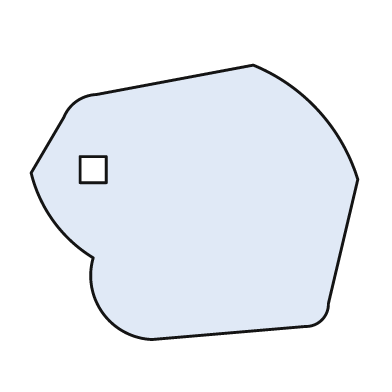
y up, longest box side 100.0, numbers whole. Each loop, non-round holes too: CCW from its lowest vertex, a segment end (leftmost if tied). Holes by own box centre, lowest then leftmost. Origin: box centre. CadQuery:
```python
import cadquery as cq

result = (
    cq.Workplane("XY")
    .moveTo(-13.0, -42.0)
    .lineTo(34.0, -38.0)
    .threePointArc((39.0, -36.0), (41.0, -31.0))
    .lineTo(50.0, 7.0)
    .threePointArc((38.0, 28.0), (18.0, 42.0))
    .lineTo(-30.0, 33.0)
    .threePointArc((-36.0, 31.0), (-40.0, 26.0))
    .lineTo(-50.0, 9.0)
    .threePointArc((-43.0, -6.0), (-31.0, -17.0))
    .threePointArc((-28.0, -34.0), (-13.0, -42.0))
    .close()
    .moveTo(-35.0, 6.0)
    .lineTo(-27.0, 6.0)
    .lineTo(-27.0, 14.0)
    .lineTo(-35.0, 14.0)
    .close()
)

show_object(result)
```